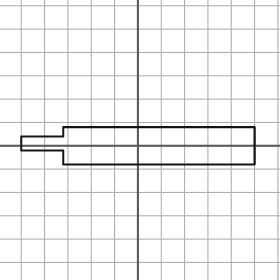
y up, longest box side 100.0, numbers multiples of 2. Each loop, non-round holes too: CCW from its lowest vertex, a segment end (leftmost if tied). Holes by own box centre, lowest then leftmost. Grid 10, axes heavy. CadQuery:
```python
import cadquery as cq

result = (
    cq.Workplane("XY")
    .moveTo(-32.0, -8.0)
    .lineTo(50.0, -8.0)
    .lineTo(50.0, 8.0)
    .lineTo(-32.0, 8.0)
    .lineTo(-32.0, 4.0)
    .lineTo(-50.0, 4.0)
    .lineTo(-50.0, -2.0)
    .lineTo(-32.0, -2.0)
    .close()
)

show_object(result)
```